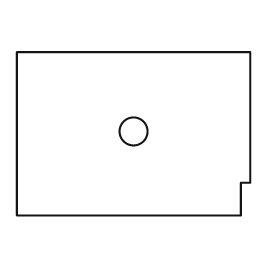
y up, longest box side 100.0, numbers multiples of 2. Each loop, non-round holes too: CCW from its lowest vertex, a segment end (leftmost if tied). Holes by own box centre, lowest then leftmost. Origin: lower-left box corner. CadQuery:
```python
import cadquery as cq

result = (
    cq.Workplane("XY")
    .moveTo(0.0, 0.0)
    .lineTo(96.0, 0.0)
    .lineTo(96.0, 14.0)
    .lineTo(100.0, 14.0)
    .lineTo(100.0, 70.0)
    .lineTo(0.0, 70.0)
    .close()
    .moveTo(50.0, 36.0)
    .circle(6.0)
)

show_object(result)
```